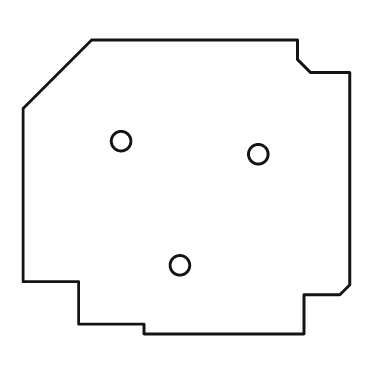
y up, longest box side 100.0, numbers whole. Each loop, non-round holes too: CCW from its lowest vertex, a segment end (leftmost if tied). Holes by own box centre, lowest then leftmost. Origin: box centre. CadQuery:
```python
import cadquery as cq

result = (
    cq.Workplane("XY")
    .moveTo(-13.0, -45.0)
    .lineTo(36.0, -45.0)
    .lineTo(36.0, -33.0)
    .lineTo(47.0, -33.0)
    .lineTo(50.0, -30.0)
    .lineTo(50.0, 35.0)
    .lineTo(38.0, 35.0)
    .lineTo(34.0, 39.0)
    .lineTo(34.0, 45.0)
    .lineTo(-29.0, 45.0)
    .lineTo(-50.0, 24.0)
    .lineTo(-50.0, -29.0)
    .lineTo(-33.0, -29.0)
    .lineTo(-33.0, -42.0)
    .lineTo(-13.0, -42.0)
    .close()
    .moveTo(-2.0, -24.0)
    .circle(3.0)
    .moveTo(22.0, 10.0)
    .circle(3.0)
    .moveTo(-20.0, 14.0)
    .circle(3.0)
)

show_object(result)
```